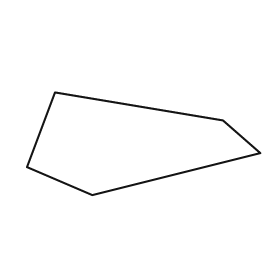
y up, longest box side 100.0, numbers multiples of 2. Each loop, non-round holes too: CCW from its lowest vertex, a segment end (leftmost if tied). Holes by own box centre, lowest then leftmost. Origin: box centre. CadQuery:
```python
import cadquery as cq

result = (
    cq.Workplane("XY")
    .moveTo(-22.0, -22.0)
    .lineTo(50.0, -4.0)
    .lineTo(34.0, 10.0)
    .lineTo(-38.0, 22.0)
    .lineTo(-50.0, -10.0)
    .close()
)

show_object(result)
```